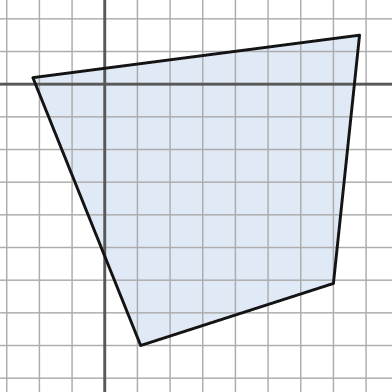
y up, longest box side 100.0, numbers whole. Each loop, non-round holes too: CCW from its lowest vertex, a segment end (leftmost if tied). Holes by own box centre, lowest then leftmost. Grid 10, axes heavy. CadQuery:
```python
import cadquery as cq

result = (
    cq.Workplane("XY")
    .moveTo(11.0, -80.0)
    .lineTo(70.0, -61.0)
    .lineTo(78.0, 15.0)
    .lineTo(-22.0, 2.0)
    .close()
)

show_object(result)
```